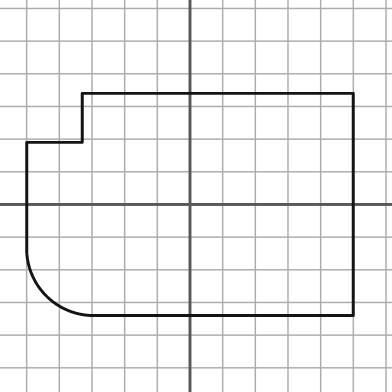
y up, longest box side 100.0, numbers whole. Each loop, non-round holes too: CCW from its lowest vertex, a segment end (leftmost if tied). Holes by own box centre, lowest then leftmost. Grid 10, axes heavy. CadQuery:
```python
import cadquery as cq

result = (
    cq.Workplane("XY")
    .moveTo(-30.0, -34.0)
    .lineTo(50.0, -34.0)
    .lineTo(50.0, 34.0)
    .lineTo(-33.0, 34.0)
    .lineTo(-33.0, 19.0)
    .lineTo(-50.0, 19.0)
    .lineTo(-50.0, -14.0)
    .threePointArc((-44.0, -28.0), (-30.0, -34.0))
    .close()
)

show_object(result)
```